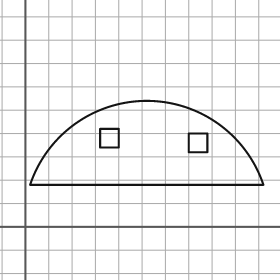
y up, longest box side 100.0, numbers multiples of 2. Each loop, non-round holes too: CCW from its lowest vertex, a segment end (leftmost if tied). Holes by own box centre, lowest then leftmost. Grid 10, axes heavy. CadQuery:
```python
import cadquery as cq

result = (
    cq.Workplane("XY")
    .moveTo(2.0, 18.0)
    .lineTo(102.0, 18.0)
    .threePointArc((52.0, 54.0), (2.0, 18.0))
    .close()
    .moveTo(70.0, 32.0)
    .lineTo(78.0, 32.0)
    .lineTo(78.0, 40.0)
    .lineTo(70.0, 40.0)
    .close()
    .moveTo(32.0, 34.0)
    .lineTo(40.0, 34.0)
    .lineTo(40.0, 42.0)
    .lineTo(32.0, 42.0)
    .close()
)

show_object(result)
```